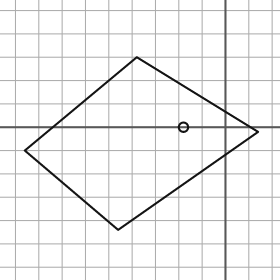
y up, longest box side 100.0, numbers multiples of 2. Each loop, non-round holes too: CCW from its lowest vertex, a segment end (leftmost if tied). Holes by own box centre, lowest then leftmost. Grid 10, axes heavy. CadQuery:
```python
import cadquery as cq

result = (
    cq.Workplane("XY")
    .moveTo(-46.0, -44.0)
    .lineTo(14.0, -2.0)
    .lineTo(-38.0, 30.0)
    .lineTo(-86.0, -10.0)
    .close()
    .moveTo(-18.0, 0.0)
    .circle(2.0)
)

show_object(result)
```